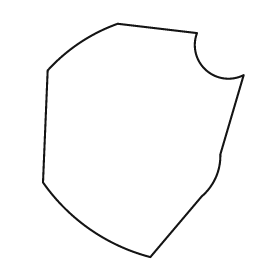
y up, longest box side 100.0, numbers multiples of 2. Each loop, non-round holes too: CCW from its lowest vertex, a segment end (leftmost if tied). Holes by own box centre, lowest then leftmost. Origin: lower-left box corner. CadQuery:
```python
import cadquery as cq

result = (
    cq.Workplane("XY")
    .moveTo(46.0, 0.0)
    .lineTo(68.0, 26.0)
    .threePointArc((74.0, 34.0), (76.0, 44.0))
    .lineTo(86.0, 78.0)
    .threePointArc((70.0, 80.0), (66.0, 96.0))
    .lineTo(32.0, 100.0)
    .threePointArc((16.0, 92.0), (2.0, 80.0))
    .lineTo(0.0, 32.0)
    .threePointArc((20.0, 12.0), (46.0, 0.0))
    .close()
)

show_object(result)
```